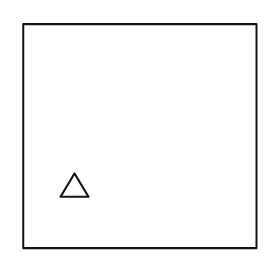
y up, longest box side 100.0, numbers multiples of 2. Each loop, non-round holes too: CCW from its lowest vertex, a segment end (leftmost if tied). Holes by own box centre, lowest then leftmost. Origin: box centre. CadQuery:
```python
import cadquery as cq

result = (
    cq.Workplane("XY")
    .moveTo(-50.0, -48.0)
    .lineTo(50.0, -48.0)
    .lineTo(50.0, 48.0)
    .lineTo(-50.0, 48.0)
    .close()
    .moveTo(-34.0, -26.0)
    .lineTo(-22.0, -26.0)
    .lineTo(-28.0, -16.0)
    .close()
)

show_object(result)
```